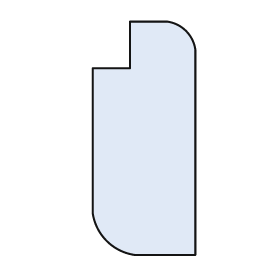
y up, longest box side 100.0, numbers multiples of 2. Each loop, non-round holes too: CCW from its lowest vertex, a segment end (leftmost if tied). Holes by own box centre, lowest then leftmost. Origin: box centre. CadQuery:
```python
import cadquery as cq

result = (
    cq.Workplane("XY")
    .moveTo(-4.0, -50.0)
    .lineTo(22.0, -50.0)
    .lineTo(22.0, 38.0)
    .threePointArc((18.0, 46.0), (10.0, 50.0))
    .lineTo(-6.0, 50.0)
    .lineTo(-6.0, 30.0)
    .lineTo(-22.0, 30.0)
    .lineTo(-22.0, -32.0)
    .threePointArc((-16.0, -44.0), (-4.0, -50.0))
    .close()
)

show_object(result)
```